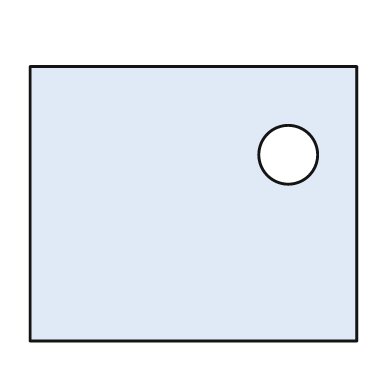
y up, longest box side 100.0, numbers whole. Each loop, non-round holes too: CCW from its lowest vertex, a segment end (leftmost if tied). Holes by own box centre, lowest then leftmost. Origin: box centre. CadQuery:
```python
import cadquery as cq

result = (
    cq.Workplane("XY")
    .moveTo(-50.0, -42.0)
    .lineTo(50.0, -42.0)
    .lineTo(50.0, 42.0)
    .lineTo(-50.0, 42.0)
    .close()
    .moveTo(29.0, 15.0)
    .circle(9.0)
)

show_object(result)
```